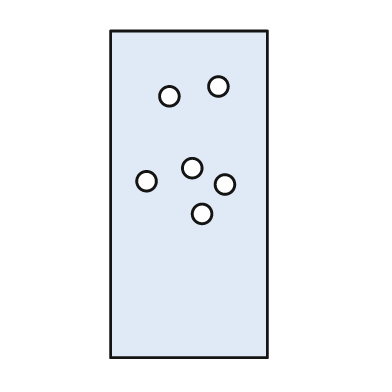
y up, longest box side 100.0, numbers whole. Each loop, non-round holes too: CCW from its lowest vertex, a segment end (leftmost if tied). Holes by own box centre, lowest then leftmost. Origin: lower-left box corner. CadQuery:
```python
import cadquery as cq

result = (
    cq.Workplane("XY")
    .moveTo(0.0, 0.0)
    .lineTo(48.0, 0.0)
    .lineTo(48.0, 100.0)
    .lineTo(0.0, 100.0)
    .close()
    .moveTo(28.0, 44.0)
    .circle(3.0)
    .moveTo(35.0, 53.0)
    .circle(3.0)
    .moveTo(11.0, 54.0)
    .circle(3.0)
    .moveTo(25.0, 58.0)
    .circle(3.0)
    .moveTo(18.0, 80.0)
    .circle(3.0)
    .moveTo(33.0, 83.0)
    .circle(3.0)
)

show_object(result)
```